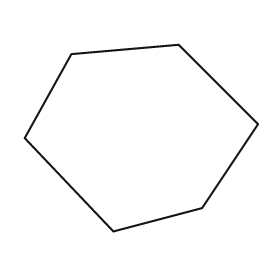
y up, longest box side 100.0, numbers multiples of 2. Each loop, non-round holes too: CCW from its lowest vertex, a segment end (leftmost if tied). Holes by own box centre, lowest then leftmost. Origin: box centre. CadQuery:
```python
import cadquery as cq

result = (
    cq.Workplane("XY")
    .moveTo(-12.0, -40.0)
    .lineTo(26.0, -30.0)
    .lineTo(50.0, 6.0)
    .lineTo(16.0, 40.0)
    .lineTo(-30.0, 36.0)
    .lineTo(-50.0, 0.0)
    .close()
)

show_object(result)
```